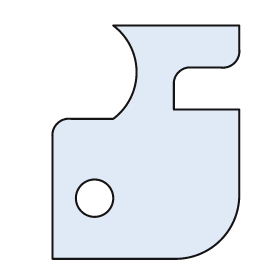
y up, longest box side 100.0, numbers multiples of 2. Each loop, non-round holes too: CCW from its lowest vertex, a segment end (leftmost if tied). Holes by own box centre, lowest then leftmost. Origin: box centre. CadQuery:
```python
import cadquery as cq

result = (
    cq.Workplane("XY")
    .moveTo(-40.0, -50.0)
    .lineTo(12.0, -50.0)
    .threePointArc((32.0, -42.0), (40.0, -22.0))
    .lineTo(40.0, 14.0)
    .lineTo(12.0, 14.0)
    .lineTo(12.0, 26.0)
    .threePointArc((14.0, 30.0), (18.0, 32.0))
    .lineTo(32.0, 32.0)
    .threePointArc((38.0, 34.0), (40.0, 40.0))
    .lineTo(40.0, 50.0)
    .lineTo(-14.0, 50.0)
    .threePointArc((-4.0, 30.0), (-14.0, 10.0))
    .lineTo(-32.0, 10.0)
    .threePointArc((-38.0, 8.0), (-40.0, 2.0))
    .close()
    .moveTo(-22.0, -24.0)
    .circle(8.0)
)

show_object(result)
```